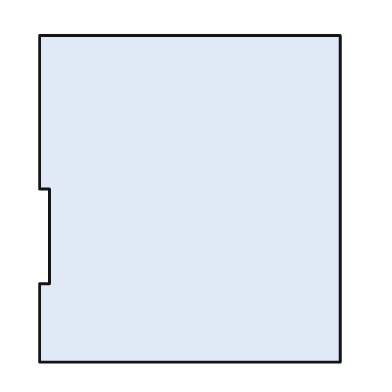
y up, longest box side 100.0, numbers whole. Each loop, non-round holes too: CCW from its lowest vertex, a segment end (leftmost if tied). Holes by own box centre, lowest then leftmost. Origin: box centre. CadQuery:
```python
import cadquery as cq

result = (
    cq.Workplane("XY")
    .moveTo(-46.0, -50.0)
    .lineTo(46.0, -50.0)
    .lineTo(46.0, 50.0)
    .lineTo(-46.0, 50.0)
    .lineTo(-46.0, 3.0)
    .lineTo(-43.0, 3.0)
    .lineTo(-43.0, -26.0)
    .lineTo(-46.0, -26.0)
    .close()
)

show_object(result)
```